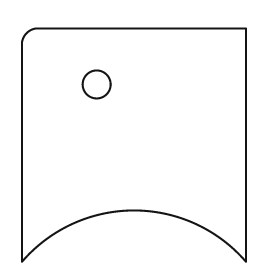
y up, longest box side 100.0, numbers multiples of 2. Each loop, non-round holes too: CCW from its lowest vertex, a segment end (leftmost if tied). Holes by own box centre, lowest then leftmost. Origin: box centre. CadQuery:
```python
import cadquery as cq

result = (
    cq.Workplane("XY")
    .moveTo(-48.0, -50.0)
    .threePointArc((0.0, -28.0), (48.0, -50.0))
    .lineTo(48.0, 50.0)
    .lineTo(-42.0, 50.0)
    .threePointArc((-46.0, 48.0), (-48.0, 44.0))
    .close()
    .moveTo(-16.0, 26.0)
    .circle(6.0)
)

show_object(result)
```